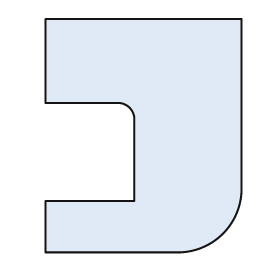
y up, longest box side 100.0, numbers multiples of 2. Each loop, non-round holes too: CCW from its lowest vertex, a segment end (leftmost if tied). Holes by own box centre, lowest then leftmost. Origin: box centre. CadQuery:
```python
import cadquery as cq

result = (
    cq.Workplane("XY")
    .moveTo(-42.0, -50.0)
    .lineTo(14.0, -50.0)
    .threePointArc((34.0, -42.0), (42.0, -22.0))
    .lineTo(42.0, 50.0)
    .lineTo(-42.0, 50.0)
    .lineTo(-42.0, 14.0)
    .lineTo(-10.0, 14.0)
    .threePointArc((-6.0, 12.0), (-4.0, 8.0))
    .lineTo(-4.0, -28.0)
    .lineTo(-42.0, -28.0)
    .close()
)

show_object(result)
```